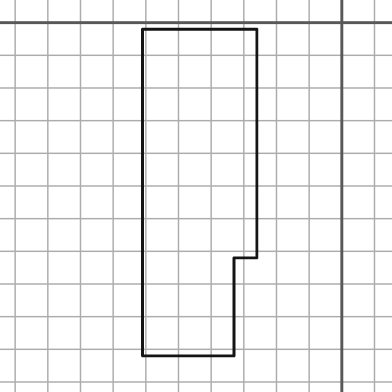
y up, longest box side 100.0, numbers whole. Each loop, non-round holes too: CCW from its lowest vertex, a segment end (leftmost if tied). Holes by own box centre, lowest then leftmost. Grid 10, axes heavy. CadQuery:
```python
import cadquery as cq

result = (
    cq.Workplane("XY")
    .moveTo(-61.0, -102.0)
    .lineTo(-33.0, -102.0)
    .lineTo(-33.0, -72.0)
    .lineTo(-26.0, -72.0)
    .lineTo(-26.0, -2.0)
    .lineTo(-61.0, -2.0)
    .close()
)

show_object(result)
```